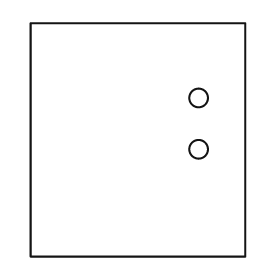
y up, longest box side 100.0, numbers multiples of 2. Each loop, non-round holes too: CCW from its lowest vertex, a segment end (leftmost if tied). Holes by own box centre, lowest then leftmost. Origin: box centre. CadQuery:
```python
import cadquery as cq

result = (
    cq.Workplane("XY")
    .moveTo(-46.0, -50.0)
    .lineTo(46.0, -50.0)
    .lineTo(46.0, 50.0)
    .lineTo(-46.0, 50.0)
    .close()
    .moveTo(26.0, -4.0)
    .circle(4.0)
    .moveTo(26.0, 18.0)
    .circle(4.0)
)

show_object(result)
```